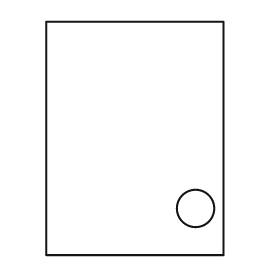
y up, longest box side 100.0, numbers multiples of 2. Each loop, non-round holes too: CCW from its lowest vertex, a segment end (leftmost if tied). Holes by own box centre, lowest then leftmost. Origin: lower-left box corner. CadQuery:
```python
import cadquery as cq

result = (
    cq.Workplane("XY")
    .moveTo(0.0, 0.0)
    .lineTo(76.0, 0.0)
    .lineTo(76.0, 100.0)
    .lineTo(0.0, 100.0)
    .close()
    .moveTo(64.0, 20.0)
    .circle(8.0)
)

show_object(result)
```